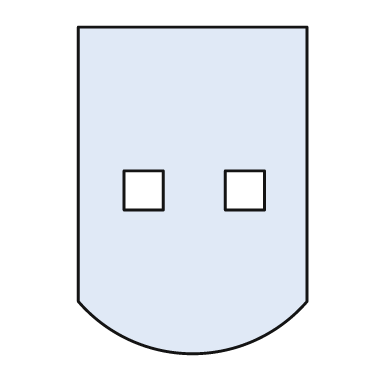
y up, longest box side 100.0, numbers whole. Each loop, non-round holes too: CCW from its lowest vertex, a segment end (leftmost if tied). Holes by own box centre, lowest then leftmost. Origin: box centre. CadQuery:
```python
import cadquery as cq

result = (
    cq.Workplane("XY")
    .moveTo(-35.0, -34.0)
    .threePointArc((0.0, -50.0), (35.0, -34.0))
    .lineTo(35.0, 50.0)
    .lineTo(-35.0, 50.0)
    .close()
    .moveTo(-21.0, -6.0)
    .lineTo(-9.0, -6.0)
    .lineTo(-9.0, 6.0)
    .lineTo(-21.0, 6.0)
    .close()
    .moveTo(10.0, -6.0)
    .lineTo(22.0, -6.0)
    .lineTo(22.0, 6.0)
    .lineTo(10.0, 6.0)
    .close()
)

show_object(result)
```